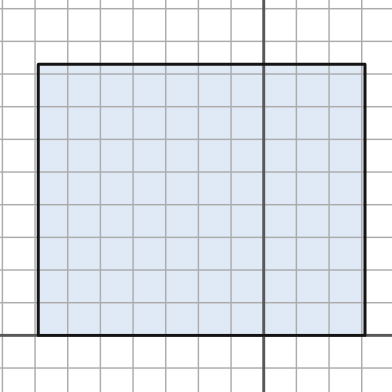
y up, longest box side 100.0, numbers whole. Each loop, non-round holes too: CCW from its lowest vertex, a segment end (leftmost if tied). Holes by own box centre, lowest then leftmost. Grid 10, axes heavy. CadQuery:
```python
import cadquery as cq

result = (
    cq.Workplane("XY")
    .moveTo(-69.0, 0.0)
    .lineTo(31.0, 0.0)
    .lineTo(31.0, 83.0)
    .lineTo(-69.0, 83.0)
    .close()
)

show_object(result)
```